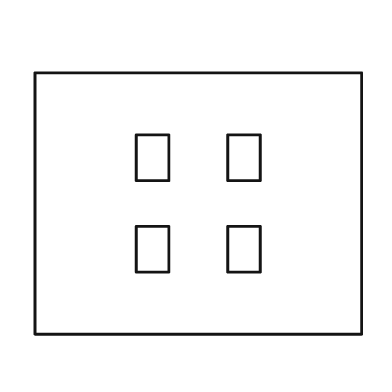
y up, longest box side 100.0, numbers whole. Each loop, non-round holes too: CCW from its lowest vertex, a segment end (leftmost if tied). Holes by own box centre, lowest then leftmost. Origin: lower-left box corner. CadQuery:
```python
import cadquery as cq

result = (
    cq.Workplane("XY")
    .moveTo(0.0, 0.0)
    .lineTo(100.0, 0.0)
    .lineTo(100.0, 80.0)
    .lineTo(0.0, 80.0)
    .close()
    .moveTo(31.0, 19.0)
    .lineTo(41.0, 19.0)
    .lineTo(41.0, 33.0)
    .lineTo(31.0, 33.0)
    .close()
    .moveTo(59.0, 19.0)
    .lineTo(69.0, 19.0)
    .lineTo(69.0, 33.0)
    .lineTo(59.0, 33.0)
    .close()
    .moveTo(31.0, 47.0)
    .lineTo(41.0, 47.0)
    .lineTo(41.0, 61.0)
    .lineTo(31.0, 61.0)
    .close()
    .moveTo(59.0, 47.0)
    .lineTo(69.0, 47.0)
    .lineTo(69.0, 61.0)
    .lineTo(59.0, 61.0)
    .close()
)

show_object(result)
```